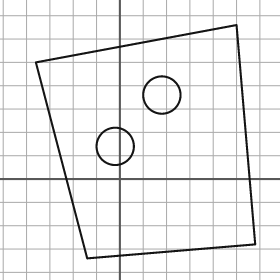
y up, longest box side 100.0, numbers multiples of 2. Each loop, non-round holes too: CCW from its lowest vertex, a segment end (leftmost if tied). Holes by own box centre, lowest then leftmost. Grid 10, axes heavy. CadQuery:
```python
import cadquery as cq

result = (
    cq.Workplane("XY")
    .moveTo(-14.0, -34.0)
    .lineTo(58.0, -28.0)
    .lineTo(50.0, 66.0)
    .lineTo(-36.0, 50.0)
    .close()
    .moveTo(-2.0, 14.0)
    .circle(8.0)
    .moveTo(18.0, 36.0)
    .circle(8.0)
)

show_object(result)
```